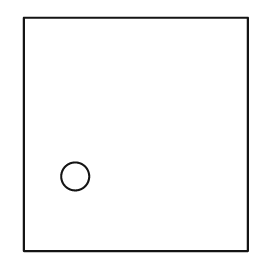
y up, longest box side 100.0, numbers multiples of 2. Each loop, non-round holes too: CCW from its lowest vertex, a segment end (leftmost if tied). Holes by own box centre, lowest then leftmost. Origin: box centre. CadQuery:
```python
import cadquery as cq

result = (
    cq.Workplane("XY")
    .moveTo(-48.0, -50.0)
    .lineTo(48.0, -50.0)
    .lineTo(48.0, 50.0)
    .lineTo(-48.0, 50.0)
    .close()
    .moveTo(-26.0, -18.0)
    .circle(6.0)
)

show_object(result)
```